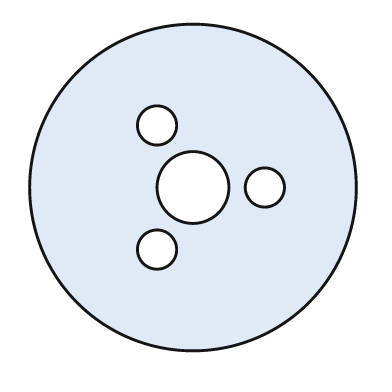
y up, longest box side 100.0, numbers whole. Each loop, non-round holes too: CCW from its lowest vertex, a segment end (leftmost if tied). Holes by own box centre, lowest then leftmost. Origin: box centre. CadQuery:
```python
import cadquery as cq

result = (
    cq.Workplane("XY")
    .moveTo(0.0, 0.0)
    .circle(50.0)
    .moveTo(-11.0, -19.0)
    .circle(6.0)
    .moveTo(0.0, 0.0)
    .circle(11.0)
    .moveTo(22.0, 0.0)
    .circle(6.0)
    .moveTo(-11.0, 19.0)
    .circle(6.0)
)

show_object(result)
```